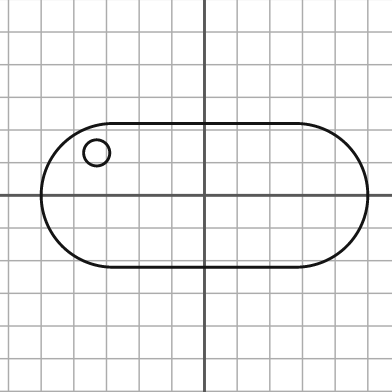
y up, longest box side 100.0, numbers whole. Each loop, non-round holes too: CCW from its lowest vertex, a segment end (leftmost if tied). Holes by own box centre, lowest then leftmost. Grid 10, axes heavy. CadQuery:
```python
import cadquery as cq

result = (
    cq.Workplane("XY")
    .moveTo(-28.0, -22.0)
    .lineTo(28.0, -22.0)
    .threePointArc((50.0, 0.0), (28.0, 22.0))
    .lineTo(-28.0, 22.0)
    .threePointArc((-50.0, 0.0), (-28.0, -22.0))
    .close()
    .moveTo(-33.0, 13.0)
    .circle(4.0)
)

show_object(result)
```